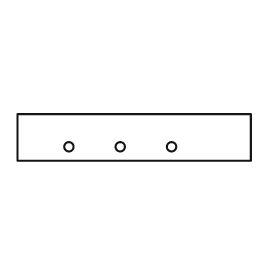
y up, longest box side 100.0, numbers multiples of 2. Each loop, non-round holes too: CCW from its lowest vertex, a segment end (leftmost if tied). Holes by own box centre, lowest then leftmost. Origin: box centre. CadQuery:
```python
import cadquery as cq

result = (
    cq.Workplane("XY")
    .moveTo(-50.0, -10.0)
    .lineTo(50.0, -10.0)
    .lineTo(50.0, 10.0)
    .lineTo(-50.0, 10.0)
    .close()
    .moveTo(-28.0, -4.0)
    .circle(2.0)
    .moveTo(-6.0, -4.0)
    .circle(2.0)
    .moveTo(16.0, -4.0)
    .circle(2.0)
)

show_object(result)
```